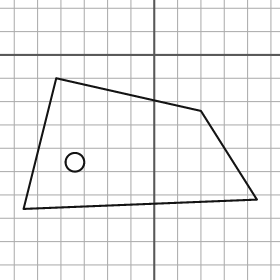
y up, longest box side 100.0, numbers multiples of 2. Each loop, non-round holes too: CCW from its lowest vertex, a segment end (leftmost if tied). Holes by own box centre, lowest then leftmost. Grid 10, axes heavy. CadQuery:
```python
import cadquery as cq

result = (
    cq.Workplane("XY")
    .moveTo(-56.0, -66.0)
    .lineTo(44.0, -62.0)
    .lineTo(20.0, -24.0)
    .lineTo(-42.0, -10.0)
    .close()
    .moveTo(-34.0, -46.0)
    .circle(4.0)
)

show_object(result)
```